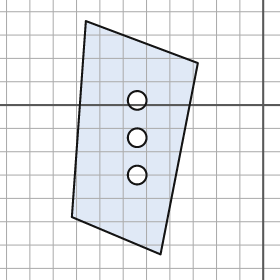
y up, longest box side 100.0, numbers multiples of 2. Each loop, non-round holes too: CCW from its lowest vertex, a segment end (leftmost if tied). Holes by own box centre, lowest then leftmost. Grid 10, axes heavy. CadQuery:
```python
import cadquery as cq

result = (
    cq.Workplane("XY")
    .moveTo(-44.0, -64.0)
    .lineTo(-28.0, 18.0)
    .lineTo(-76.0, 36.0)
    .lineTo(-82.0, -48.0)
    .close()
    .moveTo(-54.0, -30.0)
    .circle(4.0)
    .moveTo(-54.0, -14.0)
    .circle(4.0)
    .moveTo(-54.0, 2.0)
    .circle(4.0)
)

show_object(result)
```